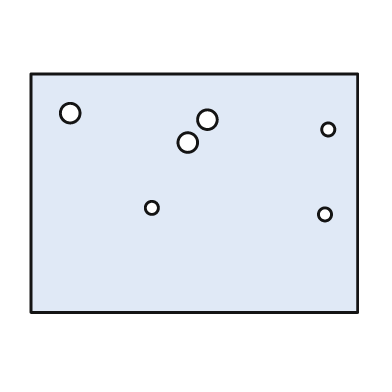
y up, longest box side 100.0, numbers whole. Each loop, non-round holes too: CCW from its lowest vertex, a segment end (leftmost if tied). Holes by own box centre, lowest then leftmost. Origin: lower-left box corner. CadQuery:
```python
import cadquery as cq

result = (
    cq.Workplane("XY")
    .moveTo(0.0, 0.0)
    .lineTo(100.0, 0.0)
    .lineTo(100.0, 73.0)
    .lineTo(0.0, 73.0)
    .close()
    .moveTo(90.0, 30.0)
    .circle(2.0)
    .moveTo(37.0, 32.0)
    .circle(2.0)
    .moveTo(48.0, 52.0)
    .circle(3.0)
    .moveTo(91.0, 56.0)
    .circle(2.0)
    .moveTo(54.0, 59.0)
    .circle(3.0)
    .moveTo(12.0, 61.0)
    .circle(3.0)
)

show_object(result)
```